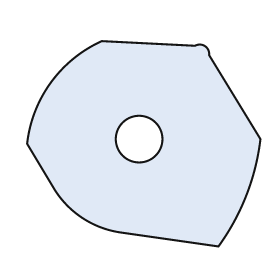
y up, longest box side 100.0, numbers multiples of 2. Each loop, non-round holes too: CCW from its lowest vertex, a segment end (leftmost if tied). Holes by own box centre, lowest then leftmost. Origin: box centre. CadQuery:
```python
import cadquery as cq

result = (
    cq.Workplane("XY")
    .moveTo(32.0, -44.0)
    .threePointArc((44.0, -22.0), (50.0, 2.0))
    .lineTo(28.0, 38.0)
    .threePointArc((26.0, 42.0), (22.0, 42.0))
    .lineTo(-18.0, 44.0)
    .threePointArc((-40.0, 26.0), (-50.0, 0.0))
    .lineTo(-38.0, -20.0)
    .threePointArc((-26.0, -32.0), (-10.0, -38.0))
    .close()
    .moveTo(-2.0, 2.0)
    .circle(10.0)
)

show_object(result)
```